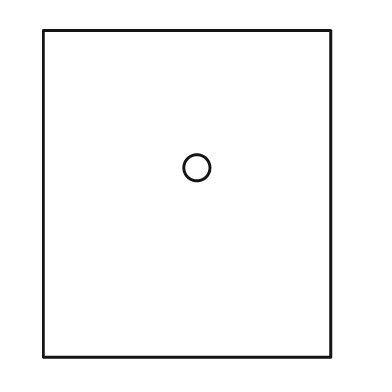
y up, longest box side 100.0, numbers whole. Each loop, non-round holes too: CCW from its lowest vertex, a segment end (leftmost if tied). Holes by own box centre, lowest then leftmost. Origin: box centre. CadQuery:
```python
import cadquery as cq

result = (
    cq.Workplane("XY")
    .moveTo(-44.0, -50.0)
    .lineTo(44.0, -50.0)
    .lineTo(44.0, 50.0)
    .lineTo(-44.0, 50.0)
    .close()
    .moveTo(3.0, 8.0)
    .circle(4.0)
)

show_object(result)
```